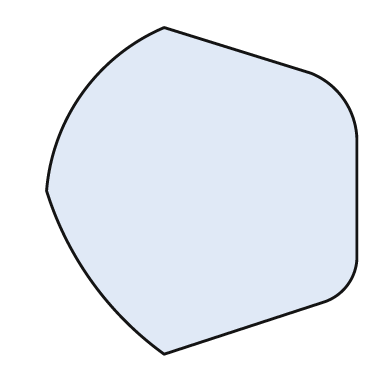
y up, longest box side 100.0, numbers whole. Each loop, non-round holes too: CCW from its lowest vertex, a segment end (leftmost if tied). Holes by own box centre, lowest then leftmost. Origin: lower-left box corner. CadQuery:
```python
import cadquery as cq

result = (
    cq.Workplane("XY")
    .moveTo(36.0, 0.0)
    .lineTo(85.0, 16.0)
    .threePointArc((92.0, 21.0), (95.0, 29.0))
    .lineTo(95.0, 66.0)
    .threePointArc((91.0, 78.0), (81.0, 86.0))
    .lineTo(36.0, 100.0)
    .threePointArc((11.0, 80.0), (0.0, 50.0))
    .threePointArc((14.0, 22.0), (36.0, 0.0))
    .close()
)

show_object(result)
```